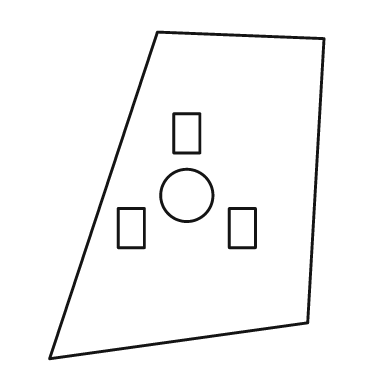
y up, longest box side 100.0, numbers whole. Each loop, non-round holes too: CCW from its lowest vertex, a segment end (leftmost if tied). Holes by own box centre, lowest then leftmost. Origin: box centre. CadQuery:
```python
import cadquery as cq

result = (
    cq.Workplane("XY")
    .moveTo(-42.0, -50.0)
    .lineTo(37.0, -39.0)
    .lineTo(42.0, 48.0)
    .lineTo(-9.0, 50.0)
    .close()
    .moveTo(-21.0, -16.0)
    .lineTo(-13.0, -16.0)
    .lineTo(-13.0, -4.0)
    .lineTo(-21.0, -4.0)
    .close()
    .moveTo(13.0, -16.0)
    .lineTo(21.0, -16.0)
    .lineTo(21.0, -4.0)
    .lineTo(13.0, -4.0)
    .close()
    .moveTo(0.0, 0.0)
    .circle(8.0)
    .moveTo(-4.0, 13.0)
    .lineTo(4.0, 13.0)
    .lineTo(4.0, 25.0)
    .lineTo(-4.0, 25.0)
    .close()
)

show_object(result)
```